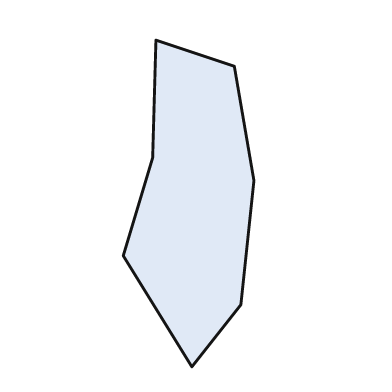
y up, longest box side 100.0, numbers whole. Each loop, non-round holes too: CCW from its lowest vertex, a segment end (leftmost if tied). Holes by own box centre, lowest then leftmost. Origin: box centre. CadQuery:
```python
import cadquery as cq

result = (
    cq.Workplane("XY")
    .moveTo(1.0, -50.0)
    .lineTo(16.0, -31.0)
    .lineTo(20.0, 7.0)
    .lineTo(14.0, 42.0)
    .lineTo(-10.0, 50.0)
    .lineTo(-11.0, 14.0)
    .lineTo(-20.0, -16.0)
    .close()
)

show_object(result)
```